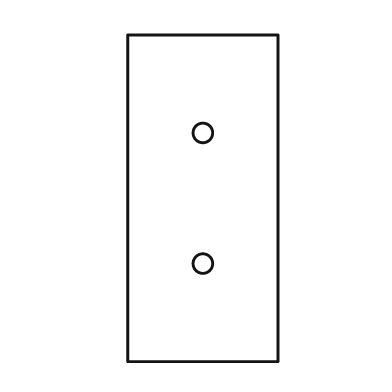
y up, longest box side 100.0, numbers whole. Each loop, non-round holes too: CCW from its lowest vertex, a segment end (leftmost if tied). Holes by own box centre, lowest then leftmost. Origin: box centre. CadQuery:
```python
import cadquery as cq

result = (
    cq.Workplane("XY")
    .moveTo(-23.0, -50.0)
    .lineTo(23.0, -50.0)
    .lineTo(23.0, 50.0)
    .lineTo(-23.0, 50.0)
    .close()
    .moveTo(0.0, -20.0)
    .circle(3.0)
    .moveTo(0.0, 20.0)
    .circle(3.0)
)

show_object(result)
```